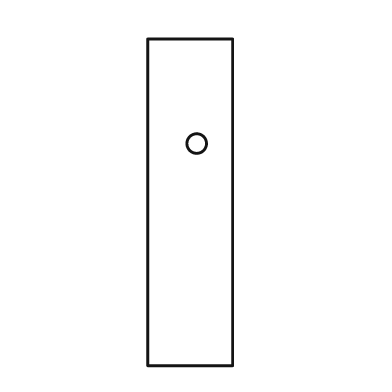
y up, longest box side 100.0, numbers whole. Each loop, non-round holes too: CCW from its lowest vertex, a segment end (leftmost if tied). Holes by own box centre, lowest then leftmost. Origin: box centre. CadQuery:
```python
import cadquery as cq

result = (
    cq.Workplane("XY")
    .moveTo(-13.0, -50.0)
    .lineTo(13.0, -50.0)
    .lineTo(13.0, 50.0)
    .lineTo(-13.0, 50.0)
    .close()
    .moveTo(2.0, 18.0)
    .circle(3.0)
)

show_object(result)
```